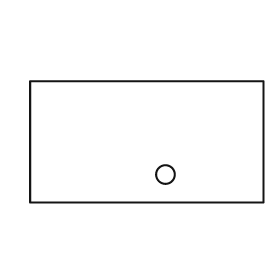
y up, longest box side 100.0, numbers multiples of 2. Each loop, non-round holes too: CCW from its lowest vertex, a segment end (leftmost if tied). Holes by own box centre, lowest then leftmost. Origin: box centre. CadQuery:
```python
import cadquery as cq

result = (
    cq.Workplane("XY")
    .moveTo(-50.0, -26.0)
    .lineTo(50.0, -26.0)
    .lineTo(50.0, 26.0)
    .lineTo(-50.0, 26.0)
    .close()
    .moveTo(8.0, -14.0)
    .circle(4.0)
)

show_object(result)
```